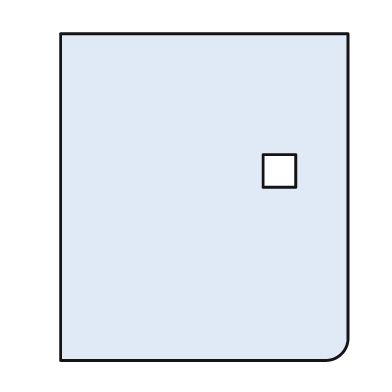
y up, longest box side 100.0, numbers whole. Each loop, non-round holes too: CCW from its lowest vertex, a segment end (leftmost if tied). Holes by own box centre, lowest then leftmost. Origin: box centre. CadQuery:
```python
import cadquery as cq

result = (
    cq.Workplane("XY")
    .moveTo(-44.0, -50.0)
    .lineTo(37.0, -50.0)
    .threePointArc((42.0, -48.0), (44.0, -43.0))
    .lineTo(44.0, 50.0)
    .lineTo(-44.0, 50.0)
    .close()
    .moveTo(18.0, 3.0)
    .lineTo(28.0, 3.0)
    .lineTo(28.0, 13.0)
    .lineTo(18.0, 13.0)
    .close()
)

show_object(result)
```